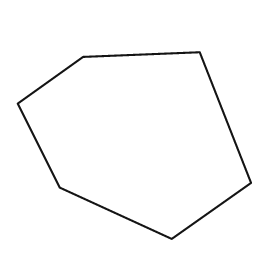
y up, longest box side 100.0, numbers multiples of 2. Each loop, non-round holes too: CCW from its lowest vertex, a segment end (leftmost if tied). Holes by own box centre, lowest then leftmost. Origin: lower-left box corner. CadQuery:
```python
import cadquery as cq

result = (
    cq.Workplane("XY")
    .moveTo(66.0, 0.0)
    .lineTo(100.0, 24.0)
    .lineTo(78.0, 80.0)
    .lineTo(28.0, 78.0)
    .lineTo(0.0, 58.0)
    .lineTo(18.0, 22.0)
    .close()
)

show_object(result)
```